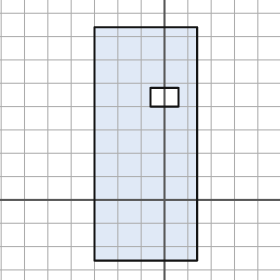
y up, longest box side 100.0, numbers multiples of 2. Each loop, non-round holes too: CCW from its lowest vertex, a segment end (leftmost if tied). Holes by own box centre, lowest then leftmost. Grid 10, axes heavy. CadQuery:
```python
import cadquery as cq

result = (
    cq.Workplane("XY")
    .moveTo(-30.0, -26.0)
    .lineTo(14.0, -26.0)
    .lineTo(14.0, 74.0)
    .lineTo(-30.0, 74.0)
    .close()
    .moveTo(-6.0, 40.0)
    .lineTo(6.0, 40.0)
    .lineTo(6.0, 48.0)
    .lineTo(-6.0, 48.0)
    .close()
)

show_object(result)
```